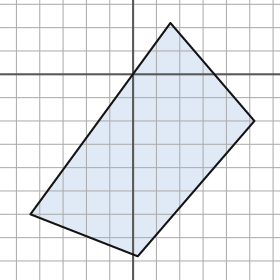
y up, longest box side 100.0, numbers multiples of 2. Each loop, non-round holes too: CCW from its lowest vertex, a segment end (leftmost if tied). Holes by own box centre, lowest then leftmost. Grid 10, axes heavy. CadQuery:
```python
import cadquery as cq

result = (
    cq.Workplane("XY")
    .moveTo(2.0, -78.0)
    .lineTo(52.0, -20.0)
    .lineTo(16.0, 22.0)
    .lineTo(-44.0, -60.0)
    .close()
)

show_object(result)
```